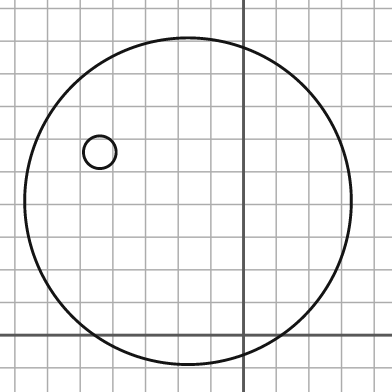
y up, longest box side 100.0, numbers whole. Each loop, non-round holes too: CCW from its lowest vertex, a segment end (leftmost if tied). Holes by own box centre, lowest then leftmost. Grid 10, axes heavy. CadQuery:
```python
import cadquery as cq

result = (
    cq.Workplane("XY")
    .moveTo(-17.0, 41.0)
    .circle(50.0)
    .moveTo(-44.0, 56.0)
    .circle(5.0)
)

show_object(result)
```